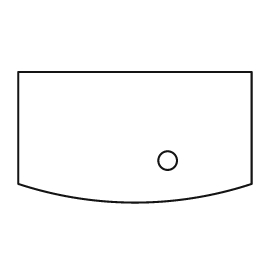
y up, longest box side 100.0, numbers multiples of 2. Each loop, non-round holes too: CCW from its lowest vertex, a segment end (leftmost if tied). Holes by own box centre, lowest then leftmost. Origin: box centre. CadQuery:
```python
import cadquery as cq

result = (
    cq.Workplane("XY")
    .moveTo(-50.0, -20.0)
    .threePointArc((0.0, -28.0), (50.0, -20.0))
    .lineTo(50.0, 28.0)
    .lineTo(-50.0, 28.0)
    .close()
    .moveTo(14.0, -10.0)
    .circle(4.0)
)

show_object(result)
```